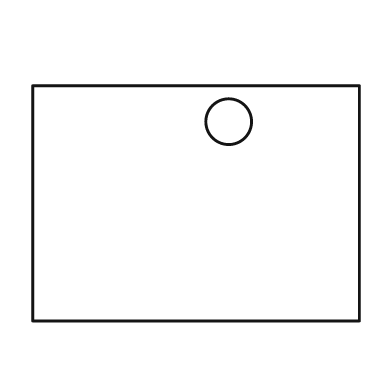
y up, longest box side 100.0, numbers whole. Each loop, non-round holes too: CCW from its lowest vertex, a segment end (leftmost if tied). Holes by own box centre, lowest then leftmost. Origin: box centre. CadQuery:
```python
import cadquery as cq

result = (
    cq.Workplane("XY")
    .moveTo(-50.0, -36.0)
    .lineTo(50.0, -36.0)
    .lineTo(50.0, 36.0)
    .lineTo(-50.0, 36.0)
    .close()
    .moveTo(10.0, 25.0)
    .circle(7.0)
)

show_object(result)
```